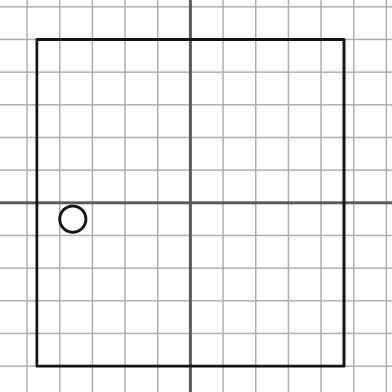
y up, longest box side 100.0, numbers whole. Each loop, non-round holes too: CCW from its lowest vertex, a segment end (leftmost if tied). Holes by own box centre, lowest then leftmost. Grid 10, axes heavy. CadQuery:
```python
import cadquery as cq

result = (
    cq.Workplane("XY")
    .moveTo(-47.0, -50.0)
    .lineTo(47.0, -50.0)
    .lineTo(47.0, 50.0)
    .lineTo(-47.0, 50.0)
    .close()
    .moveTo(-36.0, -5.0)
    .circle(4.0)
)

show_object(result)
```